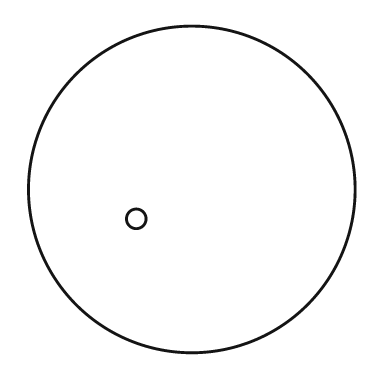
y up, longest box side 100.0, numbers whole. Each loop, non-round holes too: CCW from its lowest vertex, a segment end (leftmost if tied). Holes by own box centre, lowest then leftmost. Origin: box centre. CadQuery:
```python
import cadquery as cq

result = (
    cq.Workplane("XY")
    .moveTo(0.0, 0.0)
    .circle(50.0)
    .moveTo(-17.0, -9.0)
    .circle(3.0)
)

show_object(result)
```